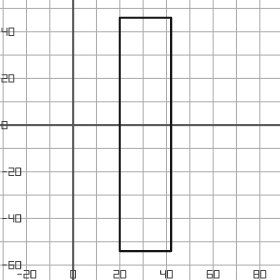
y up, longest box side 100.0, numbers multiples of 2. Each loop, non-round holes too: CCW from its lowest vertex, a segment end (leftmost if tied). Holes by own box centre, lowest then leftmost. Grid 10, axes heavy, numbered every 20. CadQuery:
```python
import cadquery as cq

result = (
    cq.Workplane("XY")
    .moveTo(20.0, -54.0)
    .lineTo(42.0, -54.0)
    .lineTo(42.0, 46.0)
    .lineTo(20.0, 46.0)
    .close()
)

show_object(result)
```